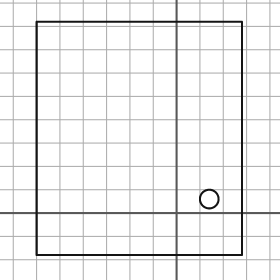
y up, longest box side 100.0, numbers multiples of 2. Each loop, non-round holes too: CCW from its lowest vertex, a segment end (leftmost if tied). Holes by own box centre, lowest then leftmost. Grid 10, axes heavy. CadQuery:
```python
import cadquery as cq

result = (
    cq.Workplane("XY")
    .moveTo(-60.0, -18.0)
    .lineTo(28.0, -18.0)
    .lineTo(28.0, 82.0)
    .lineTo(-60.0, 82.0)
    .close()
    .moveTo(14.0, 6.0)
    .circle(4.0)
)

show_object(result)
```